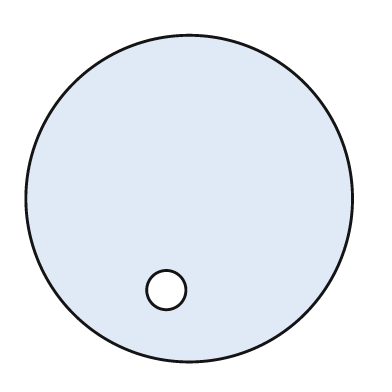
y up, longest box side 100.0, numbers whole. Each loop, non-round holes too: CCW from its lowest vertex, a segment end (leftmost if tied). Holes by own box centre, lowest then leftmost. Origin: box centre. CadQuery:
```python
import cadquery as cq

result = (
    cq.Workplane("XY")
    .moveTo(0.0, 0.0)
    .circle(50.0)
    .moveTo(-7.0, -28.0)
    .circle(6.0)
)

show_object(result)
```